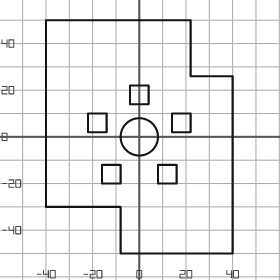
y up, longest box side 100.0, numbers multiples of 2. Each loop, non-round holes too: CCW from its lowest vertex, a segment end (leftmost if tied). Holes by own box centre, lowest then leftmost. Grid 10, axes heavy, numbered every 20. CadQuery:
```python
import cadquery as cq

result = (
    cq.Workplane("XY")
    .moveTo(-8.0, -50.0)
    .lineTo(40.0, -50.0)
    .lineTo(40.0, 26.0)
    .lineTo(22.0, 26.0)
    .lineTo(22.0, 50.0)
    .lineTo(-40.0, 50.0)
    .lineTo(-40.0, -30.0)
    .lineTo(-8.0, -30.0)
    .close()
    .moveTo(-16.0, -20.0)
    .lineTo(-8.0, -20.0)
    .lineTo(-8.0, -12.0)
    .lineTo(-16.0, -12.0)
    .close()
    .moveTo(8.0, -20.0)
    .lineTo(16.0, -20.0)
    .lineTo(16.0, -12.0)
    .lineTo(8.0, -12.0)
    .close()
    .moveTo(0.0, 0.0)
    .circle(8.0)
    .moveTo(-22.0, 2.0)
    .lineTo(-14.0, 2.0)
    .lineTo(-14.0, 10.0)
    .lineTo(-22.0, 10.0)
    .close()
    .moveTo(14.0, 2.0)
    .lineTo(22.0, 2.0)
    .lineTo(22.0, 10.0)
    .lineTo(14.0, 10.0)
    .close()
    .moveTo(-4.0, 14.0)
    .lineTo(4.0, 14.0)
    .lineTo(4.0, 22.0)
    .lineTo(-4.0, 22.0)
    .close()
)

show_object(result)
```